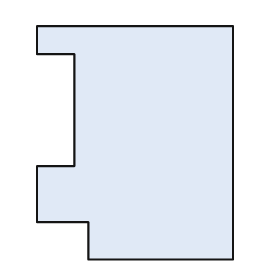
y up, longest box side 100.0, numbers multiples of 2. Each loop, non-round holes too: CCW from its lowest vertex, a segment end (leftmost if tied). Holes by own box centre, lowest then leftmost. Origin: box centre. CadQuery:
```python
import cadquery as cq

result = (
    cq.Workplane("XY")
    .moveTo(-20.0, -50.0)
    .lineTo(42.0, -50.0)
    .lineTo(42.0, 50.0)
    .lineTo(-42.0, 50.0)
    .lineTo(-42.0, 38.0)
    .lineTo(-26.0, 38.0)
    .lineTo(-26.0, -10.0)
    .lineTo(-42.0, -10.0)
    .lineTo(-42.0, -34.0)
    .lineTo(-20.0, -34.0)
    .close()
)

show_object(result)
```